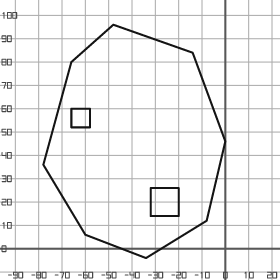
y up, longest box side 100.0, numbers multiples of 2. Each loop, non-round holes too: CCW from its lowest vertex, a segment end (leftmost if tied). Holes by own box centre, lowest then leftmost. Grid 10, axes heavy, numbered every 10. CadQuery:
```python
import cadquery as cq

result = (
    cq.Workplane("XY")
    .moveTo(-34.0, -4.0)
    .lineTo(-8.0, 12.0)
    .lineTo(0.0, 46.0)
    .lineTo(-14.0, 84.0)
    .lineTo(-48.0, 96.0)
    .lineTo(-66.0, 80.0)
    .lineTo(-78.0, 36.0)
    .lineTo(-60.0, 6.0)
    .close()
    .moveTo(-32.0, 14.0)
    .lineTo(-20.0, 14.0)
    .lineTo(-20.0, 26.0)
    .lineTo(-32.0, 26.0)
    .close()
    .moveTo(-66.0, 52.0)
    .lineTo(-58.0, 52.0)
    .lineTo(-58.0, 60.0)
    .lineTo(-66.0, 60.0)
    .close()
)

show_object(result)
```